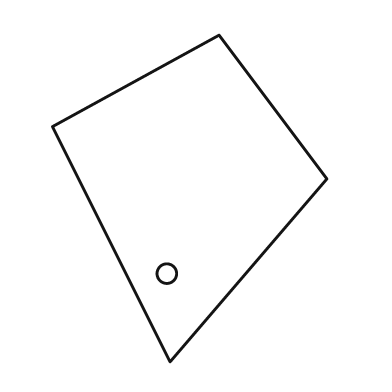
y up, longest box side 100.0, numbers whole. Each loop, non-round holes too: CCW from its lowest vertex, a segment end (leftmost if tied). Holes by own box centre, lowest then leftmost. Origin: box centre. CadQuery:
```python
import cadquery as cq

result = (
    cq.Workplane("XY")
    .moveTo(-6.0, -50.0)
    .lineTo(42.0, 6.0)
    .lineTo(9.0, 50.0)
    .lineTo(-42.0, 22.0)
    .close()
    .moveTo(-7.0, -23.0)
    .circle(3.0)
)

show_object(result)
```